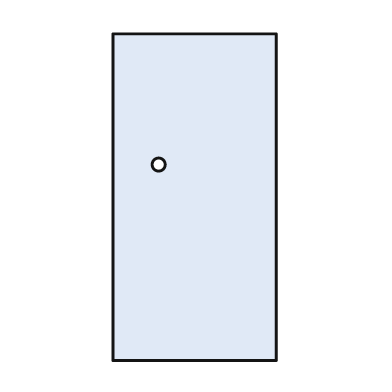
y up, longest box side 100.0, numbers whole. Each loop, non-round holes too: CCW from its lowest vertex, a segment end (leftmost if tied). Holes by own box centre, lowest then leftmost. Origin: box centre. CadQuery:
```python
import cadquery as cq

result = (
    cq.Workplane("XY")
    .moveTo(-25.0, -50.0)
    .lineTo(25.0, -50.0)
    .lineTo(25.0, 50.0)
    .lineTo(-25.0, 50.0)
    .close()
    .moveTo(-11.0, 10.0)
    .circle(2.0)
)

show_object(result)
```